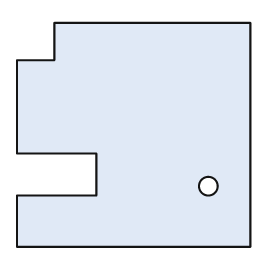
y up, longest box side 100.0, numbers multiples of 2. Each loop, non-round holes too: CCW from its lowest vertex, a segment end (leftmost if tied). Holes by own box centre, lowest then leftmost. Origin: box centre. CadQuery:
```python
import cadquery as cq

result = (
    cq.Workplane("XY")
    .moveTo(-50.0, -48.0)
    .lineTo(50.0, -48.0)
    .lineTo(50.0, 48.0)
    .lineTo(-34.0, 48.0)
    .lineTo(-34.0, 32.0)
    .lineTo(-50.0, 32.0)
    .lineTo(-50.0, -8.0)
    .lineTo(-16.0, -8.0)
    .lineTo(-16.0, -26.0)
    .lineTo(-50.0, -26.0)
    .close()
    .moveTo(32.0, -22.0)
    .circle(4.0)
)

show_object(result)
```